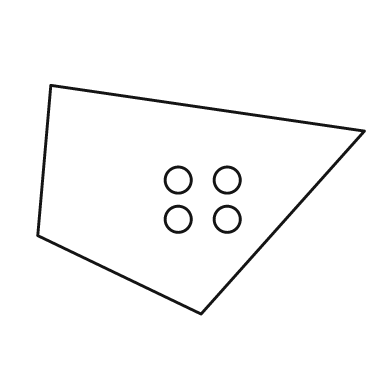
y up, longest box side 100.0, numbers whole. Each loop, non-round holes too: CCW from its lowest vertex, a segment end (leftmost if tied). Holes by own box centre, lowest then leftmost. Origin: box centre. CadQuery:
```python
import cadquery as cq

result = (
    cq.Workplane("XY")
    .moveTo(0.0, -35.0)
    .lineTo(50.0, 21.0)
    .lineTo(-46.0, 35.0)
    .lineTo(-50.0, -11.0)
    .close()
    .moveTo(-7.0, -6.0)
    .circle(4.0)
    .moveTo(8.0, -6.0)
    .circle(4.0)
    .moveTo(-7.0, 6.0)
    .circle(4.0)
    .moveTo(8.0, 6.0)
    .circle(4.0)
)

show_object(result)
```